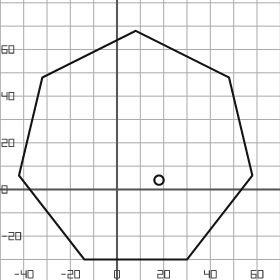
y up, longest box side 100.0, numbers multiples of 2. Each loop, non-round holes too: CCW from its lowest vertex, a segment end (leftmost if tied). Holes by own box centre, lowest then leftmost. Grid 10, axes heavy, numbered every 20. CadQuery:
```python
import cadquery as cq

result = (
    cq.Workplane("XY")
    .moveTo(-14.0, -30.0)
    .lineTo(30.0, -30.0)
    .lineTo(58.0, 6.0)
    .lineTo(48.0, 48.0)
    .lineTo(8.0, 68.0)
    .lineTo(-32.0, 48.0)
    .lineTo(-42.0, 6.0)
    .close()
    .moveTo(18.0, 4.0)
    .circle(2.0)
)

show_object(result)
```